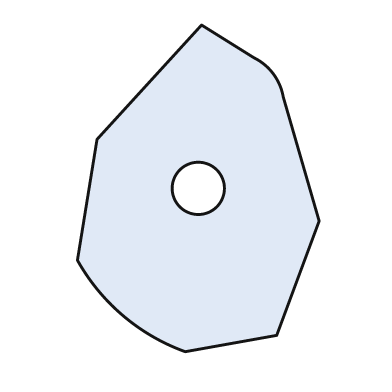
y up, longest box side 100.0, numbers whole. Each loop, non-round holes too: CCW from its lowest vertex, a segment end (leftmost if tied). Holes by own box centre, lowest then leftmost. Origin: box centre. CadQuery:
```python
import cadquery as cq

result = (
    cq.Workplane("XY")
    .moveTo(-4.0, -50.0)
    .lineTo(24.0, -45.0)
    .lineTo(37.0, -10.0)
    .lineTo(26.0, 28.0)
    .threePointArc((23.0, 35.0), (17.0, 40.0))
    .lineTo(1.0, 50.0)
    .lineTo(-31.0, 15.0)
    .lineTo(-37.0, -22.0)
    .threePointArc((-23.0, -39.0), (-4.0, -50.0))
    .close()
    .moveTo(0.0, 0.0)
    .circle(8.0)
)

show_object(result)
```